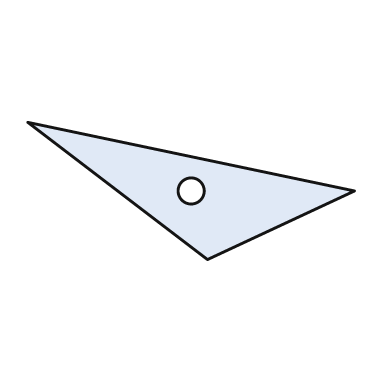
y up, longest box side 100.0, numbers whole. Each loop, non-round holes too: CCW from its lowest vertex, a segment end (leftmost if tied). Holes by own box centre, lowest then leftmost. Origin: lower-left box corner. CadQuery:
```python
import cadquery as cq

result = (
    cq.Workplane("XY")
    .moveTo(55.0, 0.0)
    .lineTo(100.0, 21.0)
    .lineTo(0.0, 42.0)
    .close()
    .moveTo(50.0, 21.0)
    .circle(4.0)
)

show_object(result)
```